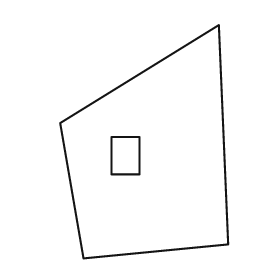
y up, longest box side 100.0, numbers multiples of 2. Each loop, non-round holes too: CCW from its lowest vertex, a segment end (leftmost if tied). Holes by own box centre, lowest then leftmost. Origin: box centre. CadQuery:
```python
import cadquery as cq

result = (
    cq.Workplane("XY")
    .moveTo(-26.0, -50.0)
    .lineTo(36.0, -44.0)
    .lineTo(32.0, 50.0)
    .lineTo(-36.0, 8.0)
    .close()
    .moveTo(-14.0, -14.0)
    .lineTo(-2.0, -14.0)
    .lineTo(-2.0, 2.0)
    .lineTo(-14.0, 2.0)
    .close()
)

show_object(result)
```